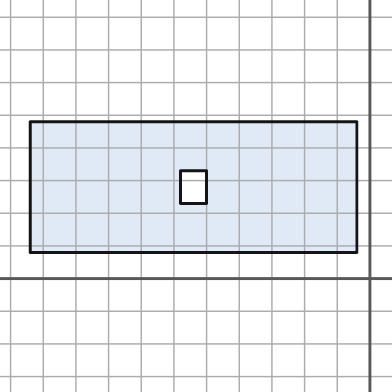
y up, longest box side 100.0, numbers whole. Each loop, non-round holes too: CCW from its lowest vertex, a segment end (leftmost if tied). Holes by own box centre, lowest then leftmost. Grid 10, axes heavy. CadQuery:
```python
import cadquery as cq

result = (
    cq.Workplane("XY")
    .moveTo(-104.0, 8.0)
    .lineTo(-4.0, 8.0)
    .lineTo(-4.0, 48.0)
    .lineTo(-104.0, 48.0)
    .close()
    .moveTo(-58.0, 23.0)
    .lineTo(-50.0, 23.0)
    .lineTo(-50.0, 33.0)
    .lineTo(-58.0, 33.0)
    .close()
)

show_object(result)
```